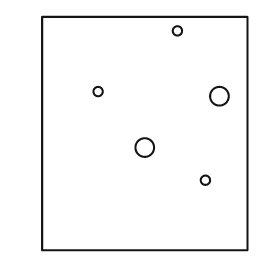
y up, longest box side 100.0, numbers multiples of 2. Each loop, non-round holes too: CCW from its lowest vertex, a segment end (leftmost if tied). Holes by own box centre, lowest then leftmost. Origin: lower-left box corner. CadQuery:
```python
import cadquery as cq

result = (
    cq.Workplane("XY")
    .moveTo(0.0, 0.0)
    .lineTo(88.0, 0.0)
    .lineTo(88.0, 100.0)
    .lineTo(0.0, 100.0)
    .close()
    .moveTo(70.0, 30.0)
    .circle(2.0)
    .moveTo(44.0, 44.0)
    .circle(4.0)
    .moveTo(76.0, 66.0)
    .circle(4.0)
    .moveTo(24.0, 68.0)
    .circle(2.0)
    .moveTo(58.0, 94.0)
    .circle(2.0)
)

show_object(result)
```